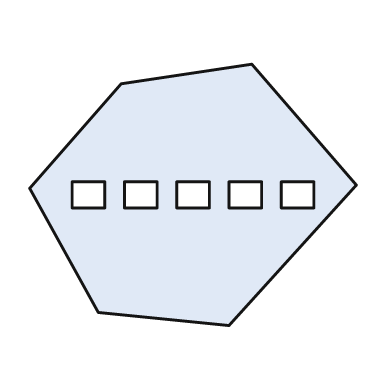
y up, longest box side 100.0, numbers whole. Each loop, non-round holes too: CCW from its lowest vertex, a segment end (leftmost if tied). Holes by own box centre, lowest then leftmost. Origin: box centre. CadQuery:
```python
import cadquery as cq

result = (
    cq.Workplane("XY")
    .moveTo(11.0, -40.0)
    .lineTo(50.0, 3.0)
    .lineTo(18.0, 40.0)
    .lineTo(-22.0, 34.0)
    .lineTo(-50.0, 2.0)
    .lineTo(-29.0, -36.0)
    .close()
    .moveTo(-37.0, -4.0)
    .lineTo(-27.0, -4.0)
    .lineTo(-27.0, 4.0)
    .lineTo(-37.0, 4.0)
    .close()
    .moveTo(-21.0, -4.0)
    .lineTo(-11.0, -4.0)
    .lineTo(-11.0, 4.0)
    .lineTo(-21.0, 4.0)
    .close()
    .moveTo(-5.0, -4.0)
    .lineTo(5.0, -4.0)
    .lineTo(5.0, 4.0)
    .lineTo(-5.0, 4.0)
    .close()
    .moveTo(11.0, -4.0)
    .lineTo(21.0, -4.0)
    .lineTo(21.0, 4.0)
    .lineTo(11.0, 4.0)
    .close()
    .moveTo(27.0, -4.0)
    .lineTo(37.0, -4.0)
    .lineTo(37.0, 4.0)
    .lineTo(27.0, 4.0)
    .close()
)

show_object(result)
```